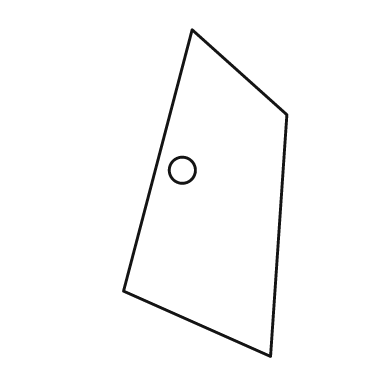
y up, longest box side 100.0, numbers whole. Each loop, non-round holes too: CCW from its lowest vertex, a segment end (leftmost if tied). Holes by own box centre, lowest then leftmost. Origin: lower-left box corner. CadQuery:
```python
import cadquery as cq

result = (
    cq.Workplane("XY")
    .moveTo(45.0, 0.0)
    .lineTo(50.0, 74.0)
    .lineTo(21.0, 100.0)
    .lineTo(0.0, 20.0)
    .close()
    .moveTo(18.0, 57.0)
    .circle(4.0)
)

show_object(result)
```